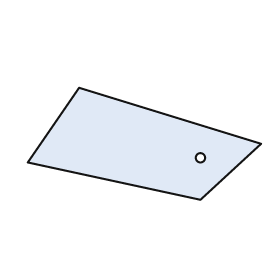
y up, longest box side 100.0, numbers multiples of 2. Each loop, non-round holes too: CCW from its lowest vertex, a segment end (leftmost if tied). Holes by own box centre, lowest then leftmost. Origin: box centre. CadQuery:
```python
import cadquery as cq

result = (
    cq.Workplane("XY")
    .moveTo(24.0, -24.0)
    .lineTo(50.0, 0.0)
    .lineTo(-28.0, 24.0)
    .lineTo(-50.0, -8.0)
    .close()
    .moveTo(24.0, -6.0)
    .circle(2.0)
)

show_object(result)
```